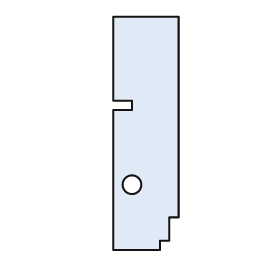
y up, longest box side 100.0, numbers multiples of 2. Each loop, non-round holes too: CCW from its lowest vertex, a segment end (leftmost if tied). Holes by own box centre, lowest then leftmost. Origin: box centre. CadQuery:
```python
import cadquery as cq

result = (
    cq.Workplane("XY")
    .moveTo(-14.0, -50.0)
    .lineTo(6.0, -50.0)
    .lineTo(6.0, -46.0)
    .lineTo(10.0, -46.0)
    .lineTo(10.0, -36.0)
    .lineTo(14.0, -36.0)
    .lineTo(14.0, 50.0)
    .lineTo(-14.0, 50.0)
    .lineTo(-14.0, 14.0)
    .lineTo(-6.0, 14.0)
    .lineTo(-6.0, 10.0)
    .lineTo(-14.0, 10.0)
    .close()
    .moveTo(-6.0, -22.0)
    .circle(4.0)
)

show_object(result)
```